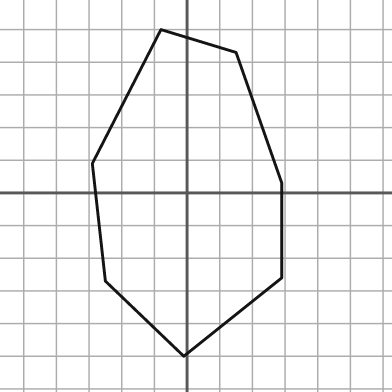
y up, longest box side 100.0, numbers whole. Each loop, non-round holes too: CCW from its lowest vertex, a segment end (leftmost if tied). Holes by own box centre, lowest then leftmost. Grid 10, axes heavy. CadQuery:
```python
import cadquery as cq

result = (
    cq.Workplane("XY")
    .moveTo(-1.0, -50.0)
    .lineTo(29.0, -26.0)
    .lineTo(29.0, 3.0)
    .lineTo(15.0, 43.0)
    .lineTo(-8.0, 50.0)
    .lineTo(-29.0, 9.0)
    .lineTo(-25.0, -27.0)
    .close()
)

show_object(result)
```